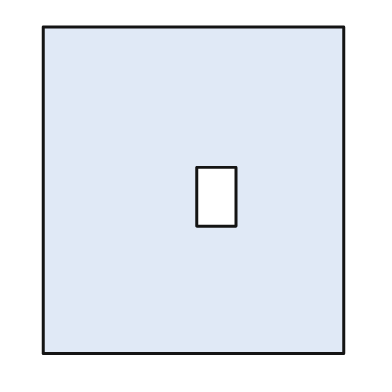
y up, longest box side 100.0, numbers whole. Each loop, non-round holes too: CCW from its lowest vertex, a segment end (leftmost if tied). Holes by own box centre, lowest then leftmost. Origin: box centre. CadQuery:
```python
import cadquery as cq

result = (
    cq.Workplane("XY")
    .moveTo(-46.0, -50.0)
    .lineTo(46.0, -50.0)
    .lineTo(46.0, 50.0)
    .lineTo(-46.0, 50.0)
    .close()
    .moveTo(1.0, -11.0)
    .lineTo(13.0, -11.0)
    .lineTo(13.0, 7.0)
    .lineTo(1.0, 7.0)
    .close()
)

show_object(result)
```